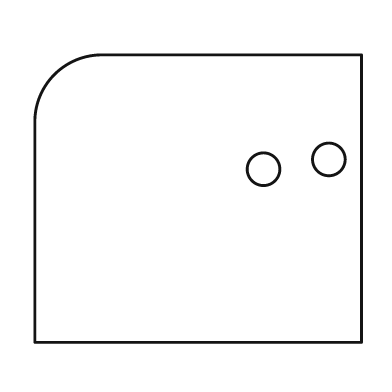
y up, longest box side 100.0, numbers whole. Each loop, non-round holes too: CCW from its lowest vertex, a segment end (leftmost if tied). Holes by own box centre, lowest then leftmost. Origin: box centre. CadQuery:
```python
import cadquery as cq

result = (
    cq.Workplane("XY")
    .moveTo(-50.0, -44.0)
    .lineTo(50.0, -44.0)
    .lineTo(50.0, 44.0)
    .lineTo(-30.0, 44.0)
    .threePointArc((-44.0, 38.0), (-50.0, 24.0))
    .close()
    .moveTo(20.0, 9.0)
    .circle(5.0)
    .moveTo(40.0, 12.0)
    .circle(5.0)
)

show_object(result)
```